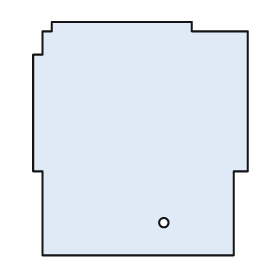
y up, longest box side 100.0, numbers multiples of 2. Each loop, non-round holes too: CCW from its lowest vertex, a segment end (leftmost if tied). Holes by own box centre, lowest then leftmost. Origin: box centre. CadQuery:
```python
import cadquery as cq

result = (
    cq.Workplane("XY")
    .moveTo(-42.0, -50.0)
    .lineTo(40.0, -50.0)
    .lineTo(40.0, -14.0)
    .lineTo(46.0, -14.0)
    .lineTo(46.0, 46.0)
    .lineTo(22.0, 46.0)
    .lineTo(22.0, 50.0)
    .lineTo(-38.0, 50.0)
    .lineTo(-38.0, 46.0)
    .lineTo(-42.0, 46.0)
    .lineTo(-42.0, 36.0)
    .lineTo(-46.0, 36.0)
    .lineTo(-46.0, -14.0)
    .lineTo(-42.0, -14.0)
    .close()
    .moveTo(10.0, -36.0)
    .circle(2.0)
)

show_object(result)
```